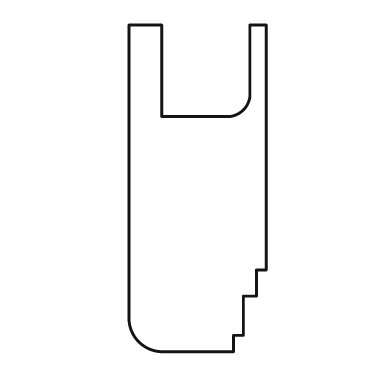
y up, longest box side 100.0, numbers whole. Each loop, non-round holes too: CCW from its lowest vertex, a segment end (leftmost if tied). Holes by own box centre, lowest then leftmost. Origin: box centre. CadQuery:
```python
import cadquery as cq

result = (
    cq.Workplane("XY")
    .moveTo(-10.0, -50.0)
    .lineTo(11.0, -50.0)
    .lineTo(11.0, -45.0)
    .lineTo(14.0, -45.0)
    .lineTo(14.0, -33.0)
    .lineTo(18.0, -33.0)
    .lineTo(18.0, -25.0)
    .lineTo(21.0, -25.0)
    .lineTo(21.0, 50.0)
    .lineTo(16.0, 50.0)
    .lineTo(16.0, 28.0)
    .threePointArc((14.0, 24.0), (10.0, 22.0))
    .lineTo(-11.0, 22.0)
    .lineTo(-11.0, 50.0)
    .lineTo(-21.0, 50.0)
    .lineTo(-21.0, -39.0)
    .threePointArc((-18.0, -47.0), (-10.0, -50.0))
    .close()
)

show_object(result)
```